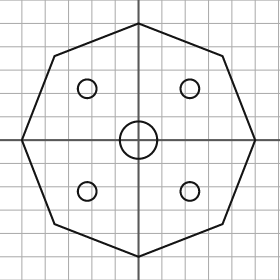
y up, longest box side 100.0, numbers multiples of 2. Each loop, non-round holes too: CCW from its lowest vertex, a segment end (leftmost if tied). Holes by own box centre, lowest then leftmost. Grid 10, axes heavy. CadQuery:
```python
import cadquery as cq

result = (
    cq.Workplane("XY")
    .moveTo(0.0, -50.0)
    .lineTo(36.0, -36.0)
    .lineTo(50.0, 0.0)
    .lineTo(36.0, 36.0)
    .lineTo(0.0, 50.0)
    .lineTo(-36.0, 36.0)
    .lineTo(-50.0, 0.0)
    .lineTo(-36.0, -36.0)
    .close()
    .moveTo(-22.0, -22.0)
    .circle(4.0)
    .moveTo(22.0, -22.0)
    .circle(4.0)
    .moveTo(0.0, 0.0)
    .circle(8.0)
    .moveTo(-22.0, 22.0)
    .circle(4.0)
    .moveTo(22.0, 22.0)
    .circle(4.0)
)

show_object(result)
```